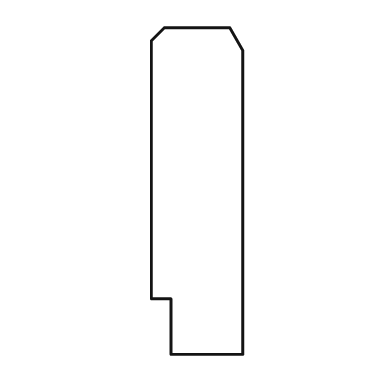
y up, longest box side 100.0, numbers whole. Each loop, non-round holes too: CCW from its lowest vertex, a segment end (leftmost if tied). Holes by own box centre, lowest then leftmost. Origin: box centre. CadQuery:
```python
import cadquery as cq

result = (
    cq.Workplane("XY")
    .moveTo(-8.0, -50.0)
    .lineTo(14.0, -50.0)
    .lineTo(14.0, 43.0)
    .lineTo(10.0, 50.0)
    .lineTo(-10.0, 50.0)
    .lineTo(-14.0, 46.0)
    .lineTo(-14.0, -33.0)
    .lineTo(-8.0, -33.0)
    .close()
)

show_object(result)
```